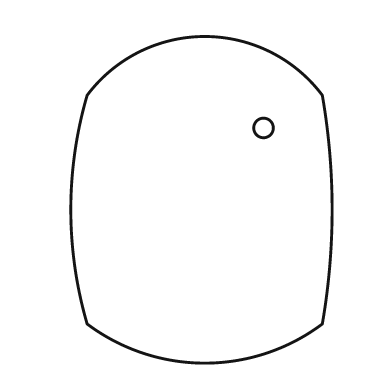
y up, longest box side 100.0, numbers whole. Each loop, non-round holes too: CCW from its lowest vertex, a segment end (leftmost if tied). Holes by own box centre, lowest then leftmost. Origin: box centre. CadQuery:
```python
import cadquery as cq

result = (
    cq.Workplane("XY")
    .moveTo(-35.0, -38.0)
    .threePointArc((1.0, -50.0), (37.0, -38.0))
    .threePointArc((40.0, -3.0), (37.0, 32.0))
    .threePointArc((1.0, 50.0), (-35.0, 32.0))
    .threePointArc((-40.0, -3.0), (-35.0, -38.0))
    .close()
    .moveTo(19.0, 22.0)
    .circle(3.0)
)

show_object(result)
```